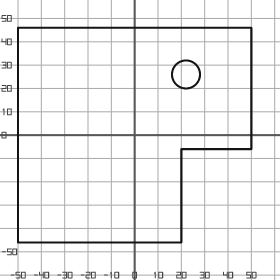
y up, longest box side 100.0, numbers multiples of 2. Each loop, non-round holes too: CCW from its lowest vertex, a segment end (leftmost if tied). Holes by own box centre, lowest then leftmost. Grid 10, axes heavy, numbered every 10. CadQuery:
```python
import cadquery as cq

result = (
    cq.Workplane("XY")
    .moveTo(-50.0, -46.0)
    .lineTo(20.0, -46.0)
    .lineTo(20.0, -6.0)
    .lineTo(50.0, -6.0)
    .lineTo(50.0, 46.0)
    .lineTo(-50.0, 46.0)
    .close()
    .moveTo(22.0, 26.0)
    .circle(6.0)
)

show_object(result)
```